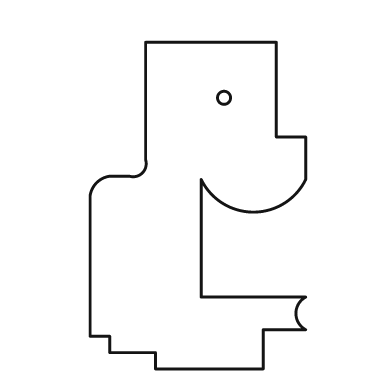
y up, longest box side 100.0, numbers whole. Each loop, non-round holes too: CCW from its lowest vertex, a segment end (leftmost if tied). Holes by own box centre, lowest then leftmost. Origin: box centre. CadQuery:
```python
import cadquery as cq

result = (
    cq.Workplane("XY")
    .moveTo(-13.0, -50.0)
    .lineTo(20.0, -50.0)
    .lineTo(20.0, -38.0)
    .lineTo(33.0, -38.0)
    .threePointArc((30.0, -33.0), (33.0, -28.0))
    .lineTo(1.0, -28.0)
    .lineTo(1.0, 8.0)
    .threePointArc((17.0, -2.0), (33.0, 8.0))
    .lineTo(33.0, 21.0)
    .lineTo(24.0, 21.0)
    .lineTo(24.0, 50.0)
    .lineTo(-16.0, 50.0)
    .lineTo(-16.0, 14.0)
    .threePointArc((-17.0, 10.0), (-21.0, 9.0))
    .lineTo(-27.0, 9.0)
    .threePointArc((-31.0, 7.0), (-33.0, 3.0))
    .lineTo(-33.0, -40.0)
    .lineTo(-27.0, -40.0)
    .lineTo(-27.0, -45.0)
    .lineTo(-13.0, -45.0)
    .close()
    .moveTo(8.0, 33.0)
    .circle(2.0)
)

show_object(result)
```